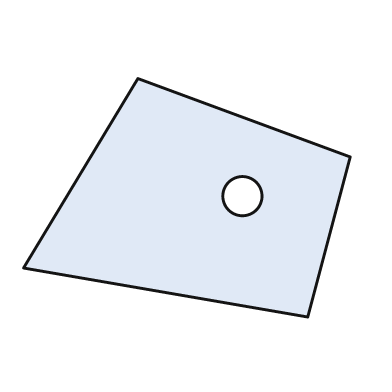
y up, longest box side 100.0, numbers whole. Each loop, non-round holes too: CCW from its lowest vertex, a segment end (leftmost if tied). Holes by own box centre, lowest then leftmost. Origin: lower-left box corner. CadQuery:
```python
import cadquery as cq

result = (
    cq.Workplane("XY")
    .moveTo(87.0, 0.0)
    .lineTo(100.0, 49.0)
    .lineTo(35.0, 73.0)
    .lineTo(0.0, 15.0)
    .close()
    .moveTo(67.0, 37.0)
    .circle(6.0)
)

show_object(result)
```